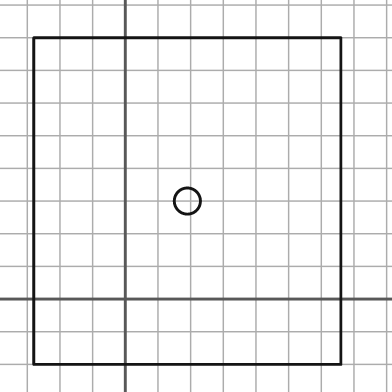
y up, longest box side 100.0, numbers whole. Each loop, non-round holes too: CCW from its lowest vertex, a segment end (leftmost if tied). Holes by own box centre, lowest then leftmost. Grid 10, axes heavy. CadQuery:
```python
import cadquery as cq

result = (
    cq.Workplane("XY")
    .moveTo(-28.0, -20.0)
    .lineTo(66.0, -20.0)
    .lineTo(66.0, 80.0)
    .lineTo(-28.0, 80.0)
    .close()
    .moveTo(19.0, 30.0)
    .circle(4.0)
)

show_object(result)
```